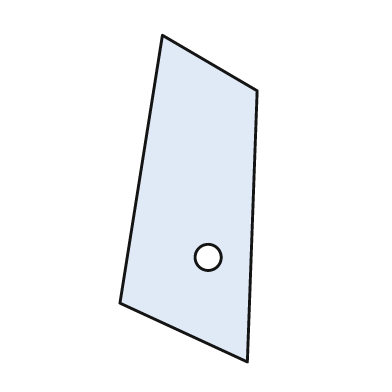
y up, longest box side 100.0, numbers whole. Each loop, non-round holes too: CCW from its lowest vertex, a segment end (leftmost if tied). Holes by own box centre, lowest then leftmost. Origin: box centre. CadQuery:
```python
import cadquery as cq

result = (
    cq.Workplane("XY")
    .moveTo(18.0, -50.0)
    .lineTo(21.0, 33.0)
    .lineTo(-8.0, 50.0)
    .lineTo(-21.0, -32.0)
    .close()
    .moveTo(6.0, -18.0)
    .circle(4.0)
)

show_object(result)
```